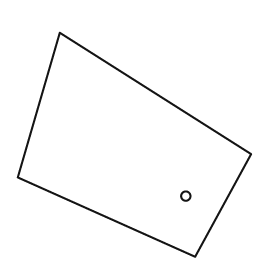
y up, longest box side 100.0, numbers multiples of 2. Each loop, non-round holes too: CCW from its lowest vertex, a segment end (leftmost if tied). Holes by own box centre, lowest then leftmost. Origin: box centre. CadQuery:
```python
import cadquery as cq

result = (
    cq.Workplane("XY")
    .moveTo(26.0, -48.0)
    .lineTo(50.0, -4.0)
    .lineTo(-32.0, 48.0)
    .lineTo(-50.0, -14.0)
    .close()
    .moveTo(22.0, -22.0)
    .circle(2.0)
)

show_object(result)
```